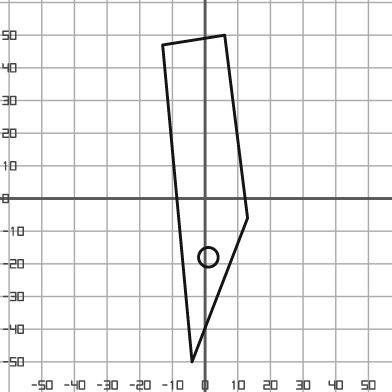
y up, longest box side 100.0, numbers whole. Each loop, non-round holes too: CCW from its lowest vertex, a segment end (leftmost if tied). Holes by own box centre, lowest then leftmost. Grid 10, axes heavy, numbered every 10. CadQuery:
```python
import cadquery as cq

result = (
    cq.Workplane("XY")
    .moveTo(-4.0, -50.0)
    .lineTo(13.0, -6.0)
    .lineTo(6.0, 50.0)
    .lineTo(-13.0, 47.0)
    .close()
    .moveTo(1.0, -18.0)
    .circle(3.0)
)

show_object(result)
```